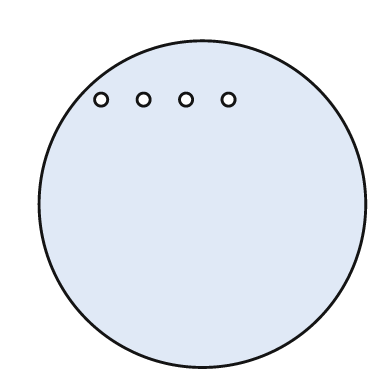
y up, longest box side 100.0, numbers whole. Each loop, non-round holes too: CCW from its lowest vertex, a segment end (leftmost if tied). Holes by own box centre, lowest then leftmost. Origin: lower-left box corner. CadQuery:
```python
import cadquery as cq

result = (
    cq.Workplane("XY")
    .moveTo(50.0, 50.0)
    .circle(50.0)
    .moveTo(19.0, 82.0)
    .circle(2.0)
    .moveTo(32.0, 82.0)
    .circle(2.0)
    .moveTo(45.0, 82.0)
    .circle(2.0)
    .moveTo(58.0, 82.0)
    .circle(2.0)
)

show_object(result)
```